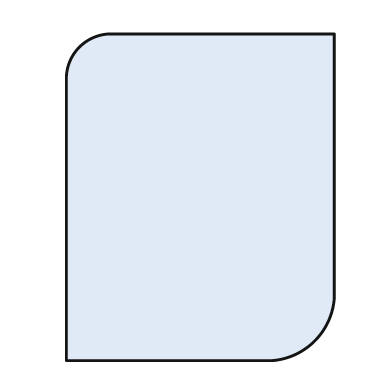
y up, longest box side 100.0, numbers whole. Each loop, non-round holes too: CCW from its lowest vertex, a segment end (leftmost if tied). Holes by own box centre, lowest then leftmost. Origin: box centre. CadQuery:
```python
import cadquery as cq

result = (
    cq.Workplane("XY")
    .moveTo(-41.0, -50.0)
    .lineTo(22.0, -50.0)
    .threePointArc((35.0, -44.0), (41.0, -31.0))
    .lineTo(41.0, 50.0)
    .lineTo(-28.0, 50.0)
    .threePointArc((-37.0, 46.0), (-41.0, 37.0))
    .close()
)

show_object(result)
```